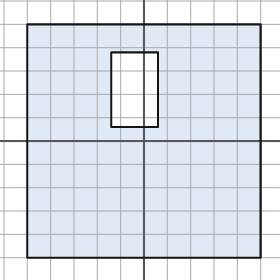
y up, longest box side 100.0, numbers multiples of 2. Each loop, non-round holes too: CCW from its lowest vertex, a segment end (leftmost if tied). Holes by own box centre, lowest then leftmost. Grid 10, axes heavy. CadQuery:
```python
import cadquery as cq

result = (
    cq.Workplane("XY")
    .moveTo(-50.0, -50.0)
    .lineTo(50.0, -50.0)
    .lineTo(50.0, 50.0)
    .lineTo(-50.0, 50.0)
    .close()
    .moveTo(-14.0, 6.0)
    .lineTo(6.0, 6.0)
    .lineTo(6.0, 38.0)
    .lineTo(-14.0, 38.0)
    .close()
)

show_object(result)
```